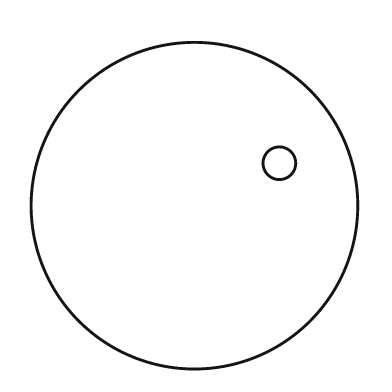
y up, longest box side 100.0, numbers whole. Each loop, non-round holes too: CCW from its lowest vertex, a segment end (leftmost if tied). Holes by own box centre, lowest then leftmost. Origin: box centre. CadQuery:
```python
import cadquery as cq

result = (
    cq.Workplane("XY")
    .moveTo(0.0, 0.0)
    .circle(50.0)
    .moveTo(26.0, 13.0)
    .circle(5.0)
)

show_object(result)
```